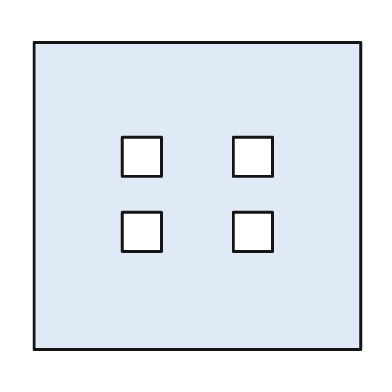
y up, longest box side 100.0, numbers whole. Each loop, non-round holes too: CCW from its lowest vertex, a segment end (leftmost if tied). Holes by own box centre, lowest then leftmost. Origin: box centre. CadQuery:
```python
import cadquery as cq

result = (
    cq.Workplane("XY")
    .moveTo(-50.0, -47.0)
    .lineTo(50.0, -47.0)
    .lineTo(50.0, 47.0)
    .lineTo(-50.0, 47.0)
    .close()
    .moveTo(-23.0, -17.0)
    .lineTo(-11.0, -17.0)
    .lineTo(-11.0, -5.0)
    .lineTo(-23.0, -5.0)
    .close()
    .moveTo(11.0, -17.0)
    .lineTo(23.0, -17.0)
    .lineTo(23.0, -5.0)
    .lineTo(11.0, -5.0)
    .close()
    .moveTo(-23.0, 6.0)
    .lineTo(-11.0, 6.0)
    .lineTo(-11.0, 18.0)
    .lineTo(-23.0, 18.0)
    .close()
    .moveTo(11.0, 6.0)
    .lineTo(23.0, 6.0)
    .lineTo(23.0, 18.0)
    .lineTo(11.0, 18.0)
    .close()
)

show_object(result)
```